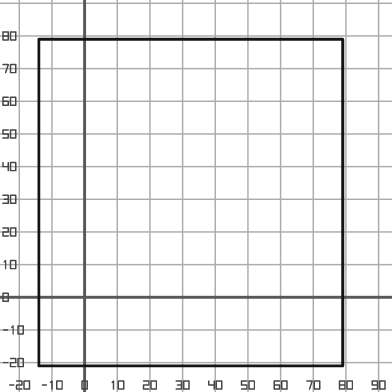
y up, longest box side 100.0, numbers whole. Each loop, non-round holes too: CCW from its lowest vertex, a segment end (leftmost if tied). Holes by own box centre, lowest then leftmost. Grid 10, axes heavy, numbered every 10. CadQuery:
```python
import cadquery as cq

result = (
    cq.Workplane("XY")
    .moveTo(-14.0, -21.0)
    .lineTo(79.0, -21.0)
    .lineTo(79.0, 79.0)
    .lineTo(-14.0, 79.0)
    .close()
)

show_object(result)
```